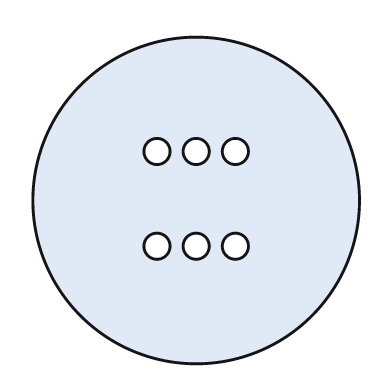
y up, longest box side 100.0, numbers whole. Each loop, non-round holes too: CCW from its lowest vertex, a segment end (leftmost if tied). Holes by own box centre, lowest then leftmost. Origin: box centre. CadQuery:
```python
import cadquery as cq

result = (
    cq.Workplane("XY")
    .moveTo(0.0, 0.0)
    .circle(50.0)
    .moveTo(-12.0, -14.0)
    .circle(4.0)
    .moveTo(0.0, -14.0)
    .circle(4.0)
    .moveTo(12.0, -14.0)
    .circle(4.0)
    .moveTo(-12.0, 15.0)
    .circle(4.0)
    .moveTo(0.0, 15.0)
    .circle(4.0)
    .moveTo(12.0, 15.0)
    .circle(4.0)
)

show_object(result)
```